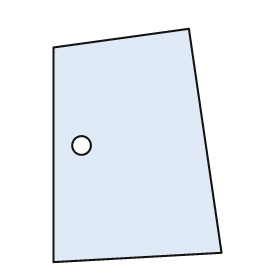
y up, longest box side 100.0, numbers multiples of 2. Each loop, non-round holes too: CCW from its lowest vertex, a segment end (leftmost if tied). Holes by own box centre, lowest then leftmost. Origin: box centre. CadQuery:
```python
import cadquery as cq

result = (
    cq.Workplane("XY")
    .moveTo(-36.0, -50.0)
    .lineTo(36.0, -46.0)
    .lineTo(22.0, 50.0)
    .lineTo(-36.0, 42.0)
    .close()
    .moveTo(-24.0, 0.0)
    .circle(4.0)
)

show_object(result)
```